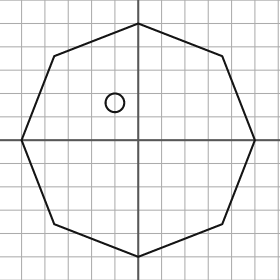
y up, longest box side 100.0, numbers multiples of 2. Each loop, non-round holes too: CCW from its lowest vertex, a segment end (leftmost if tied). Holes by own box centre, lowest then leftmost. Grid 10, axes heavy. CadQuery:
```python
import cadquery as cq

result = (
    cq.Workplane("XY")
    .moveTo(0.0, -50.0)
    .lineTo(36.0, -36.0)
    .lineTo(50.0, 0.0)
    .lineTo(36.0, 36.0)
    .lineTo(0.0, 50.0)
    .lineTo(-36.0, 36.0)
    .lineTo(-50.0, 0.0)
    .lineTo(-36.0, -36.0)
    .close()
    .moveTo(-10.0, 16.0)
    .circle(4.0)
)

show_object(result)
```